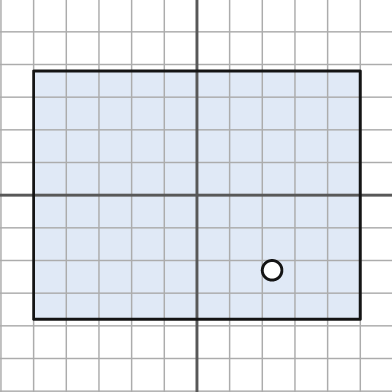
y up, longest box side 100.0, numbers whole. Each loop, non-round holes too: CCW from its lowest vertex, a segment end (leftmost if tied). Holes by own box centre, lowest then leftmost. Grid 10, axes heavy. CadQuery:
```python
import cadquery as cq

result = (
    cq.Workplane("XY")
    .moveTo(-50.0, -38.0)
    .lineTo(50.0, -38.0)
    .lineTo(50.0, 38.0)
    .lineTo(-50.0, 38.0)
    .close()
    .moveTo(23.0, -23.0)
    .circle(3.0)
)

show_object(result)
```